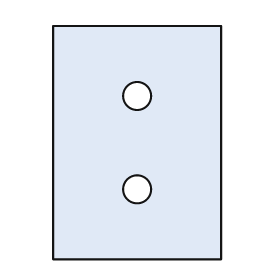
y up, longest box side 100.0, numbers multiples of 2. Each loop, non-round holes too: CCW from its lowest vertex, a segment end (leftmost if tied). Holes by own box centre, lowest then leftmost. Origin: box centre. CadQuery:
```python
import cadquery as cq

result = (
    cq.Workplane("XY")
    .moveTo(-36.0, -50.0)
    .lineTo(36.0, -50.0)
    .lineTo(36.0, 50.0)
    .lineTo(-36.0, 50.0)
    .close()
    .moveTo(0.0, -20.0)
    .circle(6.0)
    .moveTo(0.0, 20.0)
    .circle(6.0)
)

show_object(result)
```